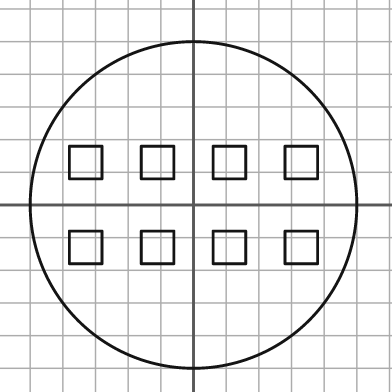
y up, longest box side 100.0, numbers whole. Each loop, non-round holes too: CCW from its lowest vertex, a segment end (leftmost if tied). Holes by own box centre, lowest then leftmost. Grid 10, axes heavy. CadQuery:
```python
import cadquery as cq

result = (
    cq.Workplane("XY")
    .moveTo(0.0, 0.0)
    .circle(50.0)
    .moveTo(-38.0, -18.0)
    .lineTo(-28.0, -18.0)
    .lineTo(-28.0, -8.0)
    .lineTo(-38.0, -8.0)
    .close()
    .moveTo(-16.0, -18.0)
    .lineTo(-6.0, -18.0)
    .lineTo(-6.0, -8.0)
    .lineTo(-16.0, -8.0)
    .close()
    .moveTo(6.0, -18.0)
    .lineTo(16.0, -18.0)
    .lineTo(16.0, -8.0)
    .lineTo(6.0, -8.0)
    .close()
    .moveTo(28.0, -18.0)
    .lineTo(38.0, -18.0)
    .lineTo(38.0, -8.0)
    .lineTo(28.0, -8.0)
    .close()
    .moveTo(-38.0, 8.0)
    .lineTo(-28.0, 8.0)
    .lineTo(-28.0, 18.0)
    .lineTo(-38.0, 18.0)
    .close()
    .moveTo(-16.0, 8.0)
    .lineTo(-6.0, 8.0)
    .lineTo(-6.0, 18.0)
    .lineTo(-16.0, 18.0)
    .close()
    .moveTo(6.0, 8.0)
    .lineTo(16.0, 8.0)
    .lineTo(16.0, 18.0)
    .lineTo(6.0, 18.0)
    .close()
    .moveTo(28.0, 8.0)
    .lineTo(38.0, 8.0)
    .lineTo(38.0, 18.0)
    .lineTo(28.0, 18.0)
    .close()
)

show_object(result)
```